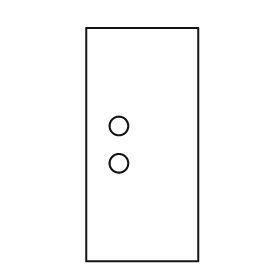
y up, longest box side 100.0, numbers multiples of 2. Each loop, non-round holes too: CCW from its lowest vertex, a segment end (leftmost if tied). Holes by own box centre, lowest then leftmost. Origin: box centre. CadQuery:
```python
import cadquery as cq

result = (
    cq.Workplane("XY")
    .moveTo(-24.0, -50.0)
    .lineTo(24.0, -50.0)
    .lineTo(24.0, 50.0)
    .lineTo(-24.0, 50.0)
    .close()
    .moveTo(-10.0, -8.0)
    .circle(4.0)
    .moveTo(-10.0, 8.0)
    .circle(4.0)
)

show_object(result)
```